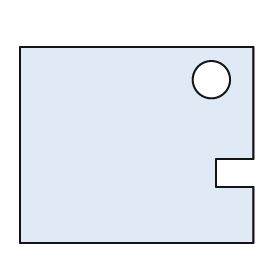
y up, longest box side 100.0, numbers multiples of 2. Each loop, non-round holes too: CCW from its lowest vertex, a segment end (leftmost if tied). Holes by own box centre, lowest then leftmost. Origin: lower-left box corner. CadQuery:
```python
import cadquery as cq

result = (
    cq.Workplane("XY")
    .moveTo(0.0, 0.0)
    .lineTo(100.0, 0.0)
    .lineTo(100.0, 24.0)
    .lineTo(84.0, 24.0)
    .lineTo(84.0, 36.0)
    .lineTo(100.0, 36.0)
    .lineTo(100.0, 84.0)
    .lineTo(0.0, 84.0)
    .close()
    .moveTo(82.0, 70.0)
    .circle(8.0)
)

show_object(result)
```